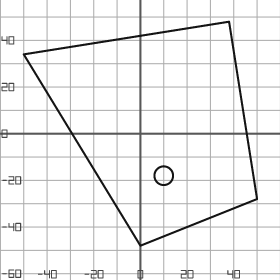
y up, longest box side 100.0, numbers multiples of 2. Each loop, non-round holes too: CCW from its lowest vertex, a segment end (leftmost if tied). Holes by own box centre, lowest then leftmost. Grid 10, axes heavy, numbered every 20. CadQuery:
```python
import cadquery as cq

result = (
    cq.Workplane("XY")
    .moveTo(0.0, -48.0)
    .lineTo(50.0, -28.0)
    .lineTo(38.0, 48.0)
    .lineTo(-50.0, 34.0)
    .close()
    .moveTo(10.0, -18.0)
    .circle(4.0)
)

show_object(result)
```